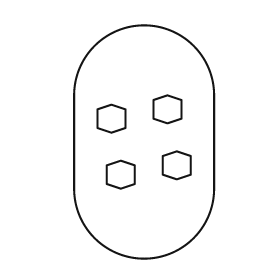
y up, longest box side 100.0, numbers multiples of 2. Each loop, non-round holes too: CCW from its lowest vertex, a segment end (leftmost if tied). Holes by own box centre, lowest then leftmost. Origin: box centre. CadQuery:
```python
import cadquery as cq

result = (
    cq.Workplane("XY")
    .moveTo(-30.0, -20.0)
    .threePointArc((0.0, -50.0), (30.0, -20.0))
    .lineTo(30.0, 20.0)
    .threePointArc((0.0, 50.0), (-30.0, 20.0))
    .close()
    .moveTo(-10.0, -20.0)
    .lineTo(-4.0, -18.0)
    .lineTo(-4.0, -10.0)
    .lineTo(-10.0, -8.0)
    .lineTo(-16.0, -10.0)
    .lineTo(-16.0, -18.0)
    .close()
    .moveTo(14.0, -16.0)
    .lineTo(20.0, -14.0)
    .lineTo(20.0, -6.0)
    .lineTo(14.0, -4.0)
    .lineTo(8.0, -6.0)
    .lineTo(8.0, -14.0)
    .close()
    .moveTo(-14.0, 4.0)
    .lineTo(-8.0, 6.0)
    .lineTo(-8.0, 14.0)
    .lineTo(-14.0, 16.0)
    .lineTo(-20.0, 14.0)
    .lineTo(-20.0, 6.0)
    .close()
    .moveTo(10.0, 8.0)
    .lineTo(16.0, 10.0)
    .lineTo(16.0, 18.0)
    .lineTo(10.0, 20.0)
    .lineTo(4.0, 18.0)
    .lineTo(4.0, 10.0)
    .close()
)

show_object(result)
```